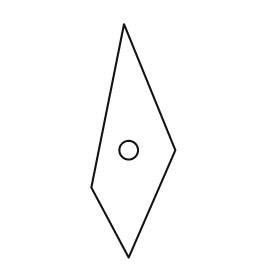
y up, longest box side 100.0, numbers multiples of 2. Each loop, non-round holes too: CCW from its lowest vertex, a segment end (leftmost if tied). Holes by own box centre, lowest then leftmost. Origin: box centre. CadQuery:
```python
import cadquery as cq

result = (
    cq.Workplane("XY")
    .moveTo(-2.0, -50.0)
    .lineTo(18.0, -4.0)
    .lineTo(-4.0, 50.0)
    .lineTo(-18.0, -20.0)
    .close()
    .moveTo(-2.0, -4.0)
    .circle(4.0)
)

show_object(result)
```